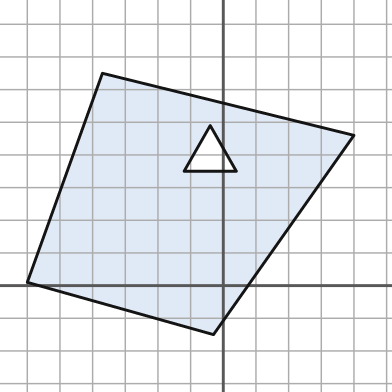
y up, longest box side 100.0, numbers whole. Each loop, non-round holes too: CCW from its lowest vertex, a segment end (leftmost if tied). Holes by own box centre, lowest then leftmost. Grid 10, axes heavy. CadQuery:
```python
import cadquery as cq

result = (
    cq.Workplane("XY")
    .moveTo(-3.0, -15.0)
    .lineTo(40.0, 46.0)
    .lineTo(-37.0, 65.0)
    .lineTo(-60.0, 1.0)
    .close()
    .moveTo(-12.0, 35.0)
    .lineTo(4.0, 35.0)
    .lineTo(-4.0, 49.0)
    .close()
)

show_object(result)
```